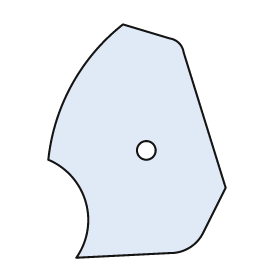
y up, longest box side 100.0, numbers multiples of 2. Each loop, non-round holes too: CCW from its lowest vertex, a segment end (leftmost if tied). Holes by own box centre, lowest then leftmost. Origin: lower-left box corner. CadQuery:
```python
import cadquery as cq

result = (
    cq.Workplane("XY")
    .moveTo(12.0, 0.0)
    .lineTo(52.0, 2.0)
    .threePointArc((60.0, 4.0), (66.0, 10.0))
    .lineTo(76.0, 30.0)
    .lineTo(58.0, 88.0)
    .threePointArc((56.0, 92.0), (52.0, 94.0))
    .lineTo(32.0, 100.0)
    .threePointArc((10.0, 74.0), (0.0, 42.0))
    .threePointArc((16.0, 24.0), (12.0, 0.0))
    .close()
    .moveTo(42.0, 46.0)
    .circle(4.0)
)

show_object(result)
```